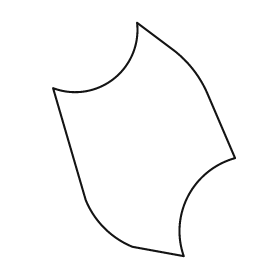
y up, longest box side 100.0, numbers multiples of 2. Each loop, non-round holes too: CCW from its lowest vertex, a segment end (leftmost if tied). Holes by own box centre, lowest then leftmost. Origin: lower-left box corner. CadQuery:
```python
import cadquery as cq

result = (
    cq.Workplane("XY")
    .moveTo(56.0, 0.0)
    .threePointArc((58.0, 26.0), (78.0, 42.0))
    .lineTo(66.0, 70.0)
    .threePointArc((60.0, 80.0), (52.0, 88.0))
    .lineTo(36.0, 100.0)
    .threePointArc((26.0, 76.0), (0.0, 72.0))
    .lineTo(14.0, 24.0)
    .threePointArc((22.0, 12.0), (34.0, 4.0))
    .close()
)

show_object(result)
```